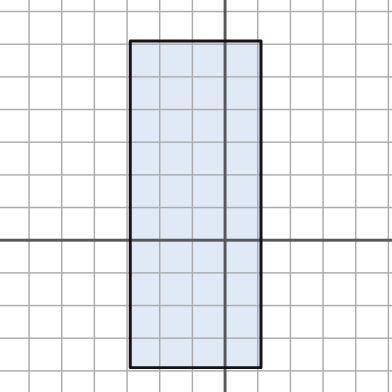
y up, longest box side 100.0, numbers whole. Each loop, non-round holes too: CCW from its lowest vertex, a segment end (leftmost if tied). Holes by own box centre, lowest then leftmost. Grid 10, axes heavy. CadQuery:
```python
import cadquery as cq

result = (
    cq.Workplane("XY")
    .moveTo(-29.0, -39.0)
    .lineTo(11.0, -39.0)
    .lineTo(11.0, 61.0)
    .lineTo(-29.0, 61.0)
    .close()
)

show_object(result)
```